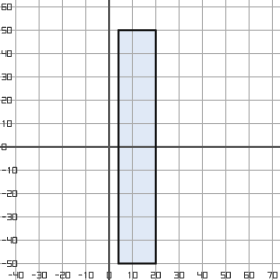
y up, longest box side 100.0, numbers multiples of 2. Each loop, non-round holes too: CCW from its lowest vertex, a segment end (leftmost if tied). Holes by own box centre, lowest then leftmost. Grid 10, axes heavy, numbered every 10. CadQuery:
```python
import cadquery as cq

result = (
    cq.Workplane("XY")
    .moveTo(4.0, -50.0)
    .lineTo(20.0, -50.0)
    .lineTo(20.0, 50.0)
    .lineTo(4.0, 50.0)
    .close()
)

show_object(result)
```